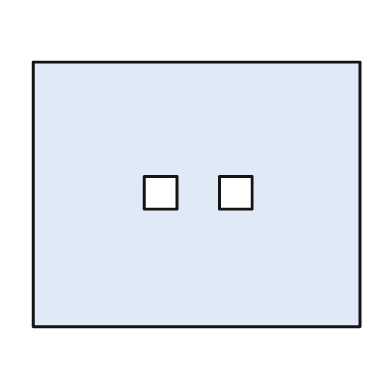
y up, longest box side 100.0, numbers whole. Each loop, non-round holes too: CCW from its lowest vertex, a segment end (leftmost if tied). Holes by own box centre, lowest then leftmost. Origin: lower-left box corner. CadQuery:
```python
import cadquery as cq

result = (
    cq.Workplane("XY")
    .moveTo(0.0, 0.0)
    .lineTo(100.0, 0.0)
    .lineTo(100.0, 81.0)
    .lineTo(0.0, 81.0)
    .close()
    .moveTo(34.0, 36.0)
    .lineTo(44.0, 36.0)
    .lineTo(44.0, 46.0)
    .lineTo(34.0, 46.0)
    .close()
    .moveTo(57.0, 36.0)
    .lineTo(67.0, 36.0)
    .lineTo(67.0, 46.0)
    .lineTo(57.0, 46.0)
    .close()
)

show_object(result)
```